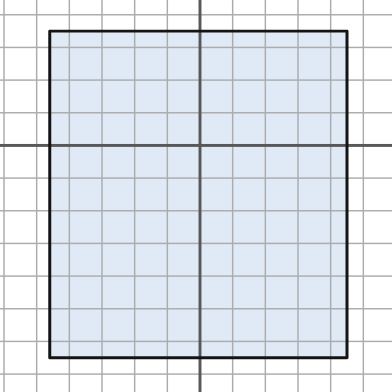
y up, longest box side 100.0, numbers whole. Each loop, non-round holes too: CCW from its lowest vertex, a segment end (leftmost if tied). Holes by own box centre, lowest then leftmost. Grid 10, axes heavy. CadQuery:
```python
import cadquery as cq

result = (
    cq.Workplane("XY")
    .moveTo(-46.0, -65.0)
    .lineTo(45.0, -65.0)
    .lineTo(45.0, 35.0)
    .lineTo(-46.0, 35.0)
    .close()
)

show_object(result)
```